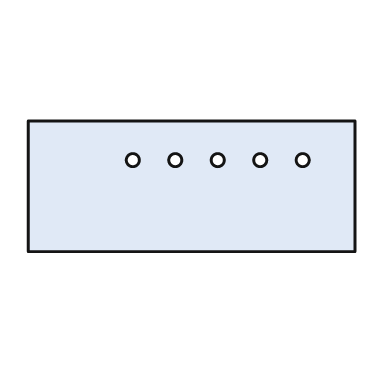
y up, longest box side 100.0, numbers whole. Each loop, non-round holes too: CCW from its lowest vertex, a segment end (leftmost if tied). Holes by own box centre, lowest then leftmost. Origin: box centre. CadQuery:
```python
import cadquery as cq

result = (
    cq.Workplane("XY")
    .moveTo(-50.0, -20.0)
    .lineTo(50.0, -20.0)
    .lineTo(50.0, 20.0)
    .lineTo(-50.0, 20.0)
    .close()
    .moveTo(-18.0, 8.0)
    .circle(2.0)
    .moveTo(-5.0, 8.0)
    .circle(2.0)
    .moveTo(8.0, 8.0)
    .circle(2.0)
    .moveTo(21.0, 8.0)
    .circle(2.0)
    .moveTo(34.0, 8.0)
    .circle(2.0)
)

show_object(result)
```